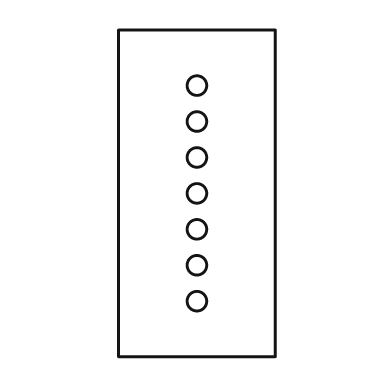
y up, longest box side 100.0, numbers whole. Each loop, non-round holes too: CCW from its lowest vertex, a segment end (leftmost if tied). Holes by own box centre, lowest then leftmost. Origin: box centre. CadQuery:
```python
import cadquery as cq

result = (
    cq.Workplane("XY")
    .moveTo(-24.0, -50.0)
    .lineTo(24.0, -50.0)
    .lineTo(24.0, 50.0)
    .lineTo(-24.0, 50.0)
    .close()
    .moveTo(0.0, -33.0)
    .circle(3.0)
    .moveTo(0.0, -22.0)
    .circle(3.0)
    .moveTo(0.0, -11.0)
    .circle(3.0)
    .moveTo(0.0, 0.0)
    .circle(3.0)
    .moveTo(0.0, 11.0)
    .circle(3.0)
    .moveTo(0.0, 22.0)
    .circle(3.0)
    .moveTo(0.0, 33.0)
    .circle(3.0)
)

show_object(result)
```